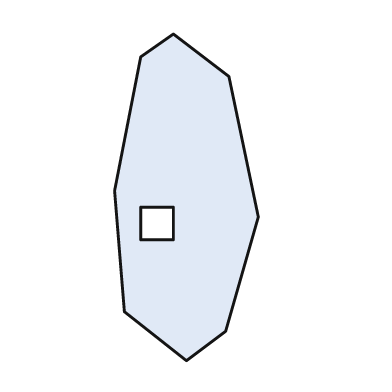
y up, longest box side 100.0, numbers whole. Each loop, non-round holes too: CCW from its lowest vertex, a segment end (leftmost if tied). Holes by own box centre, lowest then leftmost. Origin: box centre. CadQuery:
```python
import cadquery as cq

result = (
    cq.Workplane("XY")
    .moveTo(0.0, -50.0)
    .lineTo(12.0, -41.0)
    .lineTo(22.0, -6.0)
    .lineTo(13.0, 37.0)
    .lineTo(-4.0, 50.0)
    .lineTo(-14.0, 43.0)
    .lineTo(-22.0, 2.0)
    .lineTo(-19.0, -35.0)
    .close()
    .moveTo(-14.0, -13.0)
    .lineTo(-4.0, -13.0)
    .lineTo(-4.0, -3.0)
    .lineTo(-14.0, -3.0)
    .close()
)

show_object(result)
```